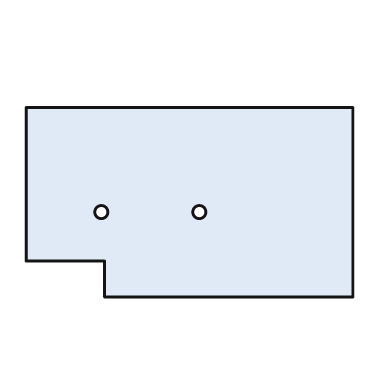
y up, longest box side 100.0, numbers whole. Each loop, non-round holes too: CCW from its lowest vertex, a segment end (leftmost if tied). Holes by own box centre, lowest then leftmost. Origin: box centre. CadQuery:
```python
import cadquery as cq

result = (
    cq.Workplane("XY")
    .moveTo(-26.0, -29.0)
    .lineTo(50.0, -29.0)
    .lineTo(50.0, 29.0)
    .lineTo(-50.0, 29.0)
    .lineTo(-50.0, -18.0)
    .lineTo(-26.0, -18.0)
    .close()
    .moveTo(-27.0, -3.0)
    .circle(2.0)
    .moveTo(3.0, -3.0)
    .circle(2.0)
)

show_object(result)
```